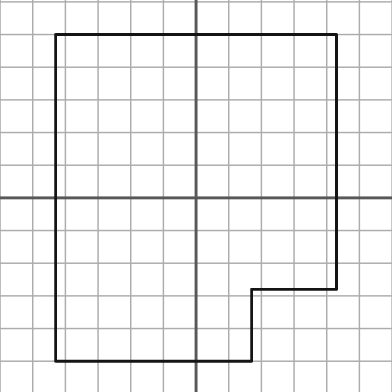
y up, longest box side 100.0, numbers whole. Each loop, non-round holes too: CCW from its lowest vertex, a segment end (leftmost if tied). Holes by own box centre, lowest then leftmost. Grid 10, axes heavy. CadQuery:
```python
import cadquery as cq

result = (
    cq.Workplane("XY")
    .moveTo(-43.0, -50.0)
    .lineTo(17.0, -50.0)
    .lineTo(17.0, -28.0)
    .lineTo(43.0, -28.0)
    .lineTo(43.0, 50.0)
    .lineTo(-43.0, 50.0)
    .close()
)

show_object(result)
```